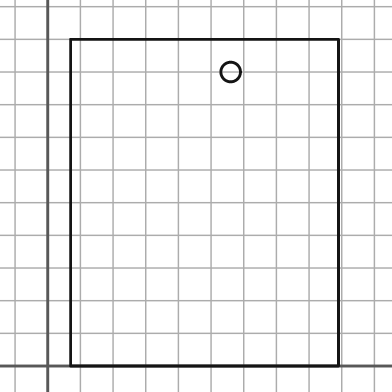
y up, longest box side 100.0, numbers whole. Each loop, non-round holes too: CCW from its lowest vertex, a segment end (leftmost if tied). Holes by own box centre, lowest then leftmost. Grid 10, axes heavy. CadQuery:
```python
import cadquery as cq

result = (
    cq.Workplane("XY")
    .moveTo(7.0, 0.0)
    .lineTo(89.0, 0.0)
    .lineTo(89.0, 100.0)
    .lineTo(7.0, 100.0)
    .close()
    .moveTo(56.0, 90.0)
    .circle(3.0)
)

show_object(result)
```